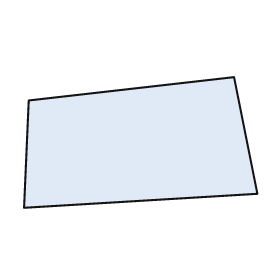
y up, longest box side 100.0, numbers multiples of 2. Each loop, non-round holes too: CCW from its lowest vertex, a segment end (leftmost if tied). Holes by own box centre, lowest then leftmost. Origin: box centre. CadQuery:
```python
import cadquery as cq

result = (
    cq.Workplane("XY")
    .moveTo(-50.0, -28.0)
    .lineTo(50.0, -22.0)
    .lineTo(40.0, 28.0)
    .lineTo(-48.0, 18.0)
    .close()
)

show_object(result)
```